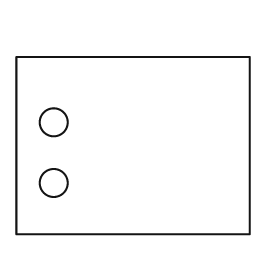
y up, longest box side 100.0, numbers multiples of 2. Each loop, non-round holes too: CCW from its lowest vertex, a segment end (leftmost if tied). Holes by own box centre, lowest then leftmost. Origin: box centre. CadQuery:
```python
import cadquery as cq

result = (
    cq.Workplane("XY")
    .moveTo(-50.0, -38.0)
    .lineTo(50.0, -38.0)
    .lineTo(50.0, 38.0)
    .lineTo(-50.0, 38.0)
    .close()
    .moveTo(-34.0, -16.0)
    .circle(6.0)
    .moveTo(-34.0, 10.0)
    .circle(6.0)
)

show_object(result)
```